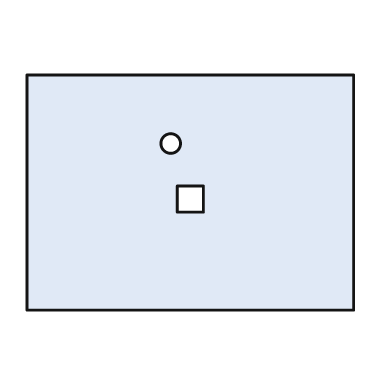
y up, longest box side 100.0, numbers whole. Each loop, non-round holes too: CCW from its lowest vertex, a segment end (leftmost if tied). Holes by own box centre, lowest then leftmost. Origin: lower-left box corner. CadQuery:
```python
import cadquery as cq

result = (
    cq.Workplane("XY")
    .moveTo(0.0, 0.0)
    .lineTo(100.0, 0.0)
    .lineTo(100.0, 72.0)
    .lineTo(0.0, 72.0)
    .close()
    .moveTo(46.0, 30.0)
    .lineTo(54.0, 30.0)
    .lineTo(54.0, 38.0)
    .lineTo(46.0, 38.0)
    .close()
    .moveTo(44.0, 51.0)
    .circle(3.0)
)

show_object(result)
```